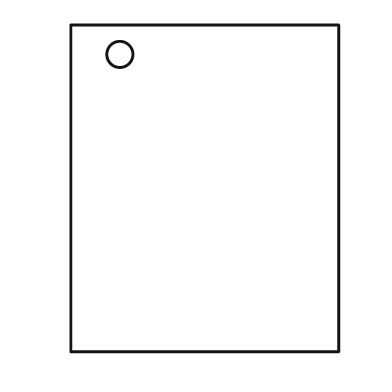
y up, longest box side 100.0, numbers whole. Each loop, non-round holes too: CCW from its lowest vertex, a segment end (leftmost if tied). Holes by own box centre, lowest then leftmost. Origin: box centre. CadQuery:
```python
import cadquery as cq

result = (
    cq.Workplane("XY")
    .moveTo(-41.0, -50.0)
    .lineTo(41.0, -50.0)
    .lineTo(41.0, 50.0)
    .lineTo(-41.0, 50.0)
    .close()
    .moveTo(-26.0, 41.0)
    .circle(4.0)
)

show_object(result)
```